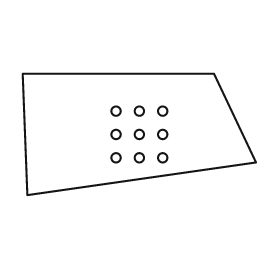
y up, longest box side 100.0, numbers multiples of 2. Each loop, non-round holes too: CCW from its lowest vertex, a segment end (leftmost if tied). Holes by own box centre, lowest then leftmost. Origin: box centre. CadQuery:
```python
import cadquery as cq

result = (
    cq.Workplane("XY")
    .moveTo(-48.0, -26.0)
    .lineTo(50.0, -12.0)
    .lineTo(32.0, 26.0)
    .lineTo(-50.0, 26.0)
    .close()
    .moveTo(-10.0, -10.0)
    .circle(2.0)
    .moveTo(0.0, -10.0)
    .circle(2.0)
    .moveTo(10.0, -10.0)
    .circle(2.0)
    .moveTo(-10.0, 0.0)
    .circle(2.0)
    .moveTo(0.0, 0.0)
    .circle(2.0)
    .moveTo(10.0, 0.0)
    .circle(2.0)
    .moveTo(-10.0, 10.0)
    .circle(2.0)
    .moveTo(0.0, 10.0)
    .circle(2.0)
    .moveTo(10.0, 10.0)
    .circle(2.0)
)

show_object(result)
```